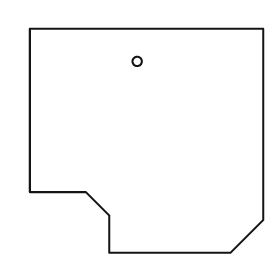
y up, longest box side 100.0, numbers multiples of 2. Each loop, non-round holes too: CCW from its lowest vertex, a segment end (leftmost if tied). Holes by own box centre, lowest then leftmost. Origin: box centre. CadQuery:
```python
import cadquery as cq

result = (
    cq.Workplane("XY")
    .moveTo(-16.0, -48.0)
    .lineTo(36.0, -48.0)
    .lineTo(50.0, -34.0)
    .lineTo(50.0, 48.0)
    .lineTo(-50.0, 48.0)
    .lineTo(-50.0, -22.0)
    .lineTo(-26.0, -22.0)
    .lineTo(-16.0, -32.0)
    .close()
    .moveTo(-4.0, 34.0)
    .circle(2.0)
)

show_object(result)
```